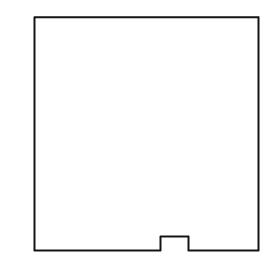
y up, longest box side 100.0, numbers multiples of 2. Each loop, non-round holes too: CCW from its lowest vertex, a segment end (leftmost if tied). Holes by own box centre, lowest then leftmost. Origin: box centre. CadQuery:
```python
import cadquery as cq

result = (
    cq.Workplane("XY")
    .moveTo(-48.0, -50.0)
    .lineTo(6.0, -50.0)
    .lineTo(6.0, -44.0)
    .lineTo(18.0, -44.0)
    .lineTo(18.0, -50.0)
    .lineTo(48.0, -50.0)
    .lineTo(48.0, 50.0)
    .lineTo(-48.0, 50.0)
    .close()
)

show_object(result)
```